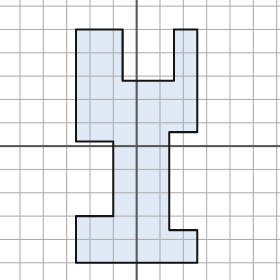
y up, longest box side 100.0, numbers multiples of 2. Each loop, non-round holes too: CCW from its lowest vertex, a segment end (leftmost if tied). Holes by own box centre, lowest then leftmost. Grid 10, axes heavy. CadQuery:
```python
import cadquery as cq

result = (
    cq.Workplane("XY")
    .moveTo(-26.0, -50.0)
    .lineTo(26.0, -50.0)
    .lineTo(26.0, -36.0)
    .lineTo(14.0, -36.0)
    .lineTo(14.0, 6.0)
    .lineTo(26.0, 6.0)
    .lineTo(26.0, 50.0)
    .lineTo(16.0, 50.0)
    .lineTo(16.0, 28.0)
    .lineTo(-6.0, 28.0)
    .lineTo(-6.0, 50.0)
    .lineTo(-26.0, 50.0)
    .lineTo(-26.0, 2.0)
    .lineTo(-10.0, 2.0)
    .lineTo(-10.0, -30.0)
    .lineTo(-26.0, -30.0)
    .close()
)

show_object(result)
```